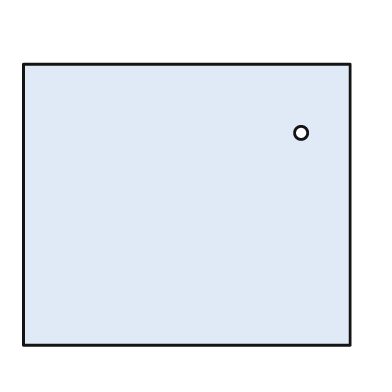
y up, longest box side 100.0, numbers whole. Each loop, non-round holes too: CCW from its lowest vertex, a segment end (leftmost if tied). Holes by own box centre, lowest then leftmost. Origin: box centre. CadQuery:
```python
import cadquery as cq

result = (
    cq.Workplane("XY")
    .moveTo(-50.0, -43.0)
    .lineTo(50.0, -43.0)
    .lineTo(50.0, 43.0)
    .lineTo(-50.0, 43.0)
    .close()
    .moveTo(35.0, 22.0)
    .circle(2.0)
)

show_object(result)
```